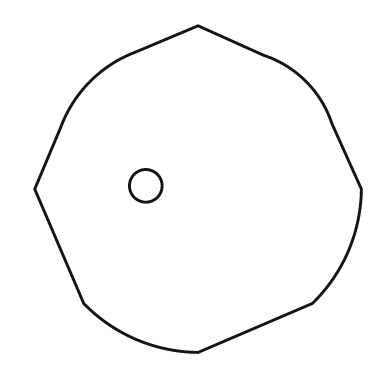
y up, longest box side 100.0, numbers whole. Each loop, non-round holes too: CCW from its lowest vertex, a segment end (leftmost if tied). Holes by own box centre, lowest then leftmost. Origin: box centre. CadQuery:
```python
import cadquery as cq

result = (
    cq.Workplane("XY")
    .moveTo(0.0, -50.0)
    .lineTo(35.0, -35.0)
    .threePointArc((46.0, -19.0), (50.0, 0.0))
    .lineTo(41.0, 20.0)
    .threePointArc((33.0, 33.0), (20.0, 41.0))
    .lineTo(0.0, 50.0)
    .lineTo(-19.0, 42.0)
    .threePointArc((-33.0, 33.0), (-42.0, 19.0))
    .lineTo(-50.0, 0.0)
    .lineTo(-35.0, -35.0)
    .threePointArc((-19.0, -46.0), (0.0, -50.0))
    .close()
    .moveTo(-16.0, 1.0)
    .circle(5.0)
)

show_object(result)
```